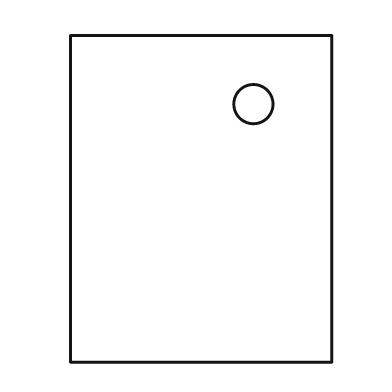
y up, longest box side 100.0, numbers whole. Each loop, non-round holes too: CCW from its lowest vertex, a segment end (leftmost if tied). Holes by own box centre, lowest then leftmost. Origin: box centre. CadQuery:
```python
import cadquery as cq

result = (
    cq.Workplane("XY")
    .moveTo(-40.0, -50.0)
    .lineTo(40.0, -50.0)
    .lineTo(40.0, 50.0)
    .lineTo(-40.0, 50.0)
    .close()
    .moveTo(16.0, 29.0)
    .circle(6.0)
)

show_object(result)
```